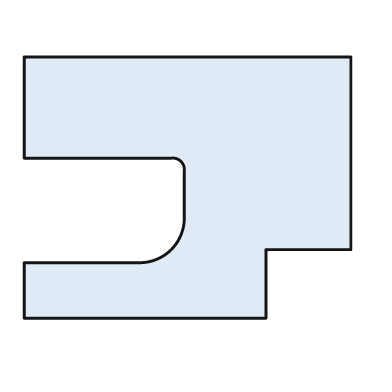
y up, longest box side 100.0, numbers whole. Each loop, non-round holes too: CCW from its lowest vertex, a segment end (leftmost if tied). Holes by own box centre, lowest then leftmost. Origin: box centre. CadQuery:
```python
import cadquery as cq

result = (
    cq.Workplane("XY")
    .moveTo(-50.0, -40.0)
    .lineTo(24.0, -40.0)
    .lineTo(24.0, -19.0)
    .lineTo(50.0, -19.0)
    .lineTo(50.0, 40.0)
    .lineTo(-50.0, 40.0)
    .lineTo(-50.0, 9.0)
    .lineTo(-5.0, 9.0)
    .threePointArc((-2.0, 8.0), (-1.0, 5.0))
    .lineTo(-1.0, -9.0)
    .threePointArc((-5.0, -19.0), (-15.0, -23.0))
    .lineTo(-50.0, -23.0)
    .close()
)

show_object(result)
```